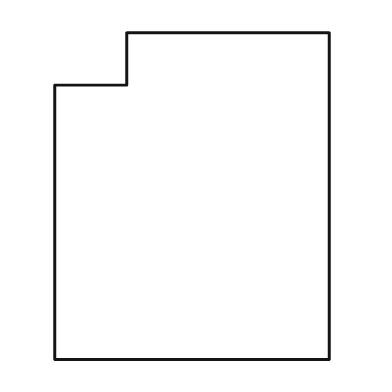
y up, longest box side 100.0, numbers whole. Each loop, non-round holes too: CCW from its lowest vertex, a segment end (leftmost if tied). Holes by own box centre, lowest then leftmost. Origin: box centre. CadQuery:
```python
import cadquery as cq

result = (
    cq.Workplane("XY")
    .moveTo(-42.0, -50.0)
    .lineTo(42.0, -50.0)
    .lineTo(42.0, 50.0)
    .lineTo(-20.0, 50.0)
    .lineTo(-20.0, 34.0)
    .lineTo(-42.0, 34.0)
    .close()
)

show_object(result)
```